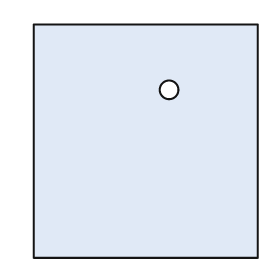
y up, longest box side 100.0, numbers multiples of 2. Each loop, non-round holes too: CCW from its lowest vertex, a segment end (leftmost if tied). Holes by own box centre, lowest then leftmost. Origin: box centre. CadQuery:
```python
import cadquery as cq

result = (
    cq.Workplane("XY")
    .moveTo(-48.0, -50.0)
    .lineTo(48.0, -50.0)
    .lineTo(48.0, 50.0)
    .lineTo(-48.0, 50.0)
    .close()
    .moveTo(10.0, 22.0)
    .circle(4.0)
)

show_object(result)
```